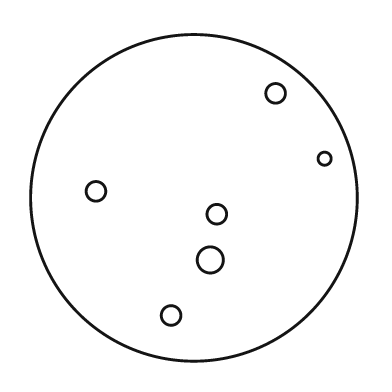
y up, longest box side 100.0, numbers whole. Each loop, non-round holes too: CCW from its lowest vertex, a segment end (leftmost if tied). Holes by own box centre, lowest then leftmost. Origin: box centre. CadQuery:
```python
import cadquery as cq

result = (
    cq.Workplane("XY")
    .moveTo(0.0, 0.0)
    .circle(50.0)
    .moveTo(-7.0, -36.0)
    .circle(3.0)
    .moveTo(5.0, -19.0)
    .circle(4.0)
    .moveTo(7.0, -5.0)
    .circle(3.0)
    .moveTo(-30.0, 2.0)
    .circle(3.0)
    .moveTo(40.0, 12.0)
    .circle(2.0)
    .moveTo(25.0, 32.0)
    .circle(3.0)
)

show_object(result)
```